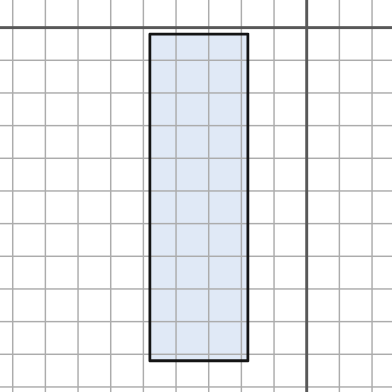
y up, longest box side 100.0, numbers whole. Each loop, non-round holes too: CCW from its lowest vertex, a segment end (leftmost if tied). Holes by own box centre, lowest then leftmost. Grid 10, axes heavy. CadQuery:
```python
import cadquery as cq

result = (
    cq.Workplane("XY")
    .moveTo(-48.0, -102.0)
    .lineTo(-18.0, -102.0)
    .lineTo(-18.0, -2.0)
    .lineTo(-48.0, -2.0)
    .close()
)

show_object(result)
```